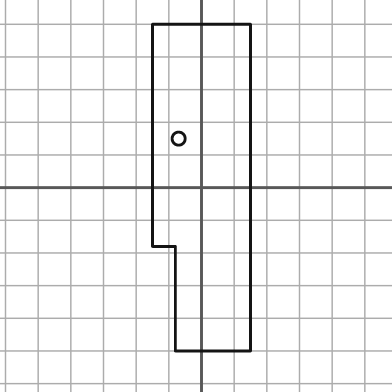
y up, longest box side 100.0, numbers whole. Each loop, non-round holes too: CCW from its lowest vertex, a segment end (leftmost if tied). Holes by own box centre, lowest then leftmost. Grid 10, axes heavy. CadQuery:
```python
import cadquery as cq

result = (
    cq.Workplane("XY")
    .moveTo(-8.0, -50.0)
    .lineTo(15.0, -50.0)
    .lineTo(15.0, 50.0)
    .lineTo(-15.0, 50.0)
    .lineTo(-15.0, -18.0)
    .lineTo(-8.0, -18.0)
    .close()
    .moveTo(-7.0, 15.0)
    .circle(2.0)
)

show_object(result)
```